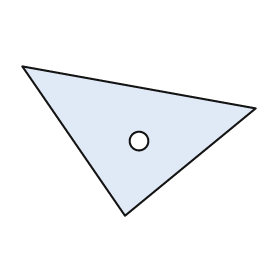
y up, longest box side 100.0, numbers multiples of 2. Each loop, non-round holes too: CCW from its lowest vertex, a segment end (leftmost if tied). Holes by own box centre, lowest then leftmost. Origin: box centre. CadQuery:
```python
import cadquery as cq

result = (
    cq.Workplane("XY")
    .moveTo(-6.0, -32.0)
    .lineTo(50.0, 14.0)
    .lineTo(-50.0, 32.0)
    .close()
    .moveTo(0.0, 0.0)
    .circle(4.0)
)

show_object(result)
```